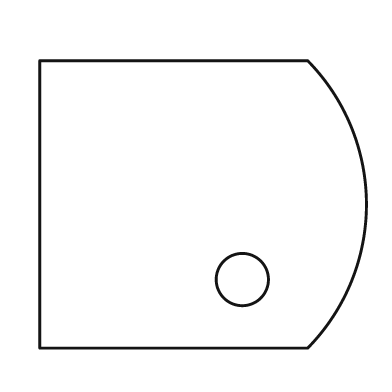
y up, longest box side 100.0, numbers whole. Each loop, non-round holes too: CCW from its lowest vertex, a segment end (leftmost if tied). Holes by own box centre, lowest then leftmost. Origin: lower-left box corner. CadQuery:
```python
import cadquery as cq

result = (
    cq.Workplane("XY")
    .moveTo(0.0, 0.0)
    .lineTo(82.0, 0.0)
    .threePointArc((100.0, 44.0), (82.0, 88.0))
    .lineTo(0.0, 88.0)
    .close()
    .moveTo(62.0, 21.0)
    .circle(8.0)
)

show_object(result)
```